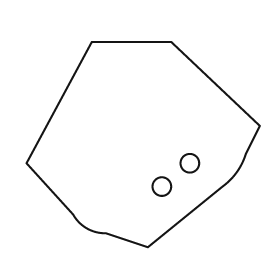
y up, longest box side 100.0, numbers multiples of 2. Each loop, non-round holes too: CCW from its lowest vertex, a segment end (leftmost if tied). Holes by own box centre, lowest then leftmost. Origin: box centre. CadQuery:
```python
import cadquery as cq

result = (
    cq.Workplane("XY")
    .moveTo(2.0, -44.0)
    .lineTo(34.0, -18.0)
    .threePointArc((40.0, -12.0), (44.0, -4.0))
    .lineTo(50.0, 8.0)
    .lineTo(12.0, 44.0)
    .lineTo(-22.0, 44.0)
    .lineTo(-50.0, -8.0)
    .lineTo(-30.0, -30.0)
    .threePointArc((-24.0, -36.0), (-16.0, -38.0))
    .close()
    .moveTo(8.0, -18.0)
    .circle(4.0)
    .moveTo(20.0, -8.0)
    .circle(4.0)
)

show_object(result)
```